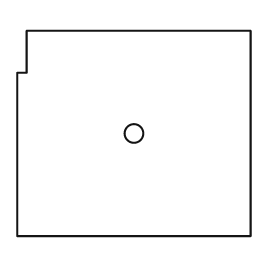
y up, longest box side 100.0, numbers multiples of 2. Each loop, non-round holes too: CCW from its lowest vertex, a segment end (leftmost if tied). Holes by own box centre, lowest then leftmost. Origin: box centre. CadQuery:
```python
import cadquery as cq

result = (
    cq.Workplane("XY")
    .moveTo(-50.0, -44.0)
    .lineTo(50.0, -44.0)
    .lineTo(50.0, 44.0)
    .lineTo(-46.0, 44.0)
    .lineTo(-46.0, 26.0)
    .lineTo(-50.0, 26.0)
    .close()
    .moveTo(0.0, 0.0)
    .circle(4.0)
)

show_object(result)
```